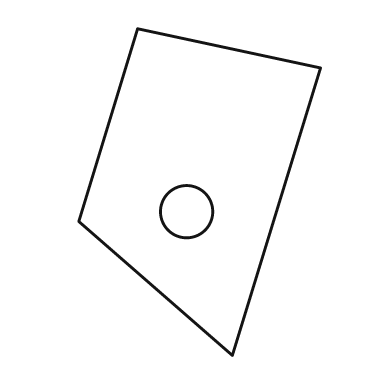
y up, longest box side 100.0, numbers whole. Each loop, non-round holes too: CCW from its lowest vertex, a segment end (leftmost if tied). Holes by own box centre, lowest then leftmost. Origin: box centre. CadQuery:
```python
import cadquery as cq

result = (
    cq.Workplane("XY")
    .moveTo(10.0, -50.0)
    .lineTo(37.0, 38.0)
    .lineTo(-19.0, 50.0)
    .lineTo(-37.0, -9.0)
    .close()
    .moveTo(-4.0, -6.0)
    .circle(8.0)
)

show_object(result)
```